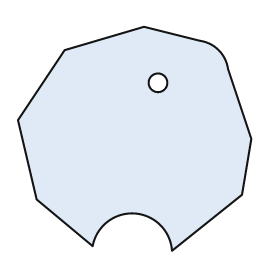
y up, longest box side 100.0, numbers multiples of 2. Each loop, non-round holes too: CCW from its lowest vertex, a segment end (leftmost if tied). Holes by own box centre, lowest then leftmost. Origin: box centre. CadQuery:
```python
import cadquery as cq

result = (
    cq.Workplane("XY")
    .moveTo(16.0, -48.0)
    .lineTo(46.0, -24.0)
    .lineTo(50.0, 0.0)
    .lineTo(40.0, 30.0)
    .threePointArc((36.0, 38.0), (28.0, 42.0))
    .lineTo(4.0, 48.0)
    .lineTo(-30.0, 38.0)
    .lineTo(-50.0, 8.0)
    .lineTo(-42.0, -26.0)
    .lineTo(-18.0, -46.0)
    .threePointArc((0.0, -32.0), (16.0, -48.0))
    .close()
    .moveTo(10.0, 24.0)
    .circle(4.0)
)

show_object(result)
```